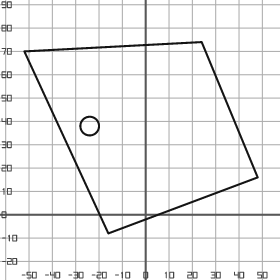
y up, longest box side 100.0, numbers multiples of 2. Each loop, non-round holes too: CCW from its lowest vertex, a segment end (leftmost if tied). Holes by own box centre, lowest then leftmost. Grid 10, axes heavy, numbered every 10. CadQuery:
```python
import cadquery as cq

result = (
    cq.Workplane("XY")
    .moveTo(-16.0, -8.0)
    .lineTo(48.0, 16.0)
    .lineTo(24.0, 74.0)
    .lineTo(-52.0, 70.0)
    .close()
    .moveTo(-24.0, 38.0)
    .circle(4.0)
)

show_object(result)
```